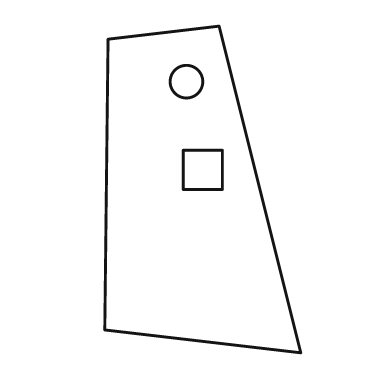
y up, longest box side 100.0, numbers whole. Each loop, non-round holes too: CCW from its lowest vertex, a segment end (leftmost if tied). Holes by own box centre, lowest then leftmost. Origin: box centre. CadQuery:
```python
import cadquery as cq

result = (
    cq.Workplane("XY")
    .moveTo(30.0, -50.0)
    .lineTo(5.0, 50.0)
    .lineTo(-29.0, 46.0)
    .lineTo(-30.0, -43.0)
    .close()
    .moveTo(-6.0, 0.0)
    .lineTo(6.0, 0.0)
    .lineTo(6.0, 12.0)
    .lineTo(-6.0, 12.0)
    .close()
    .moveTo(-5.0, 33.0)
    .circle(5.0)
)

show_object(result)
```